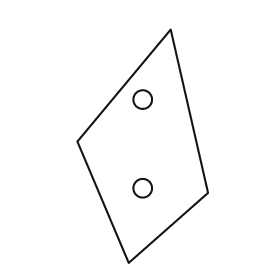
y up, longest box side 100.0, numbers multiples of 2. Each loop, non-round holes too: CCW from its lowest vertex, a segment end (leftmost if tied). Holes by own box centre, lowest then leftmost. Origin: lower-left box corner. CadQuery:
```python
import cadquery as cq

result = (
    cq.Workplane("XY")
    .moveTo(22.0, 0.0)
    .lineTo(56.0, 30.0)
    .lineTo(40.0, 100.0)
    .lineTo(0.0, 52.0)
    .close()
    .moveTo(28.0, 32.0)
    .circle(4.0)
    .moveTo(28.0, 70.0)
    .circle(4.0)
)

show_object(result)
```